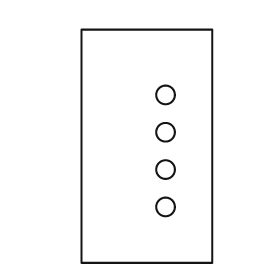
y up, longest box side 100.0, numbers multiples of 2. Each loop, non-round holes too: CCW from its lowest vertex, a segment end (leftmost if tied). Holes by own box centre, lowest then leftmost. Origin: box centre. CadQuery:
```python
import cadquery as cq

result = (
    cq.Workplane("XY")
    .moveTo(-28.0, -50.0)
    .lineTo(28.0, -50.0)
    .lineTo(28.0, 50.0)
    .lineTo(-28.0, 50.0)
    .close()
    .moveTo(8.0, -26.0)
    .circle(4.0)
    .moveTo(8.0, -10.0)
    .circle(4.0)
    .moveTo(8.0, 6.0)
    .circle(4.0)
    .moveTo(8.0, 22.0)
    .circle(4.0)
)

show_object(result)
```